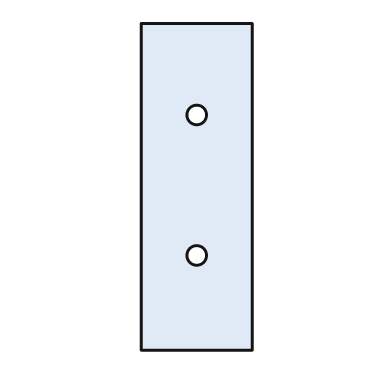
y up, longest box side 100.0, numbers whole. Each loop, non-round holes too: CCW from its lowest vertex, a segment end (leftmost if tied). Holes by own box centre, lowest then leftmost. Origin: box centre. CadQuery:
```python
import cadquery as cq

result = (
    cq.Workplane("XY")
    .moveTo(-17.0, -50.0)
    .lineTo(17.0, -50.0)
    .lineTo(17.0, 50.0)
    .lineTo(-17.0, 50.0)
    .close()
    .moveTo(0.0, -21.0)
    .circle(3.0)
    .moveTo(0.0, 22.0)
    .circle(3.0)
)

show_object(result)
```